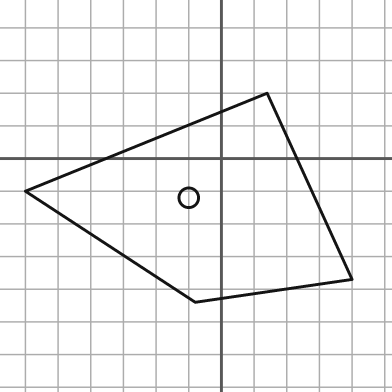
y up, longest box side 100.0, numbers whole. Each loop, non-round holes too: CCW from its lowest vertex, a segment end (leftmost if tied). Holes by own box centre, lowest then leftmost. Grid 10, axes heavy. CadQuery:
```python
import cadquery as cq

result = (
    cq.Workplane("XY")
    .moveTo(-8.0, -44.0)
    .lineTo(40.0, -37.0)
    .lineTo(14.0, 20.0)
    .lineTo(-60.0, -10.0)
    .close()
    .moveTo(-10.0, -12.0)
    .circle(3.0)
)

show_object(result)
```